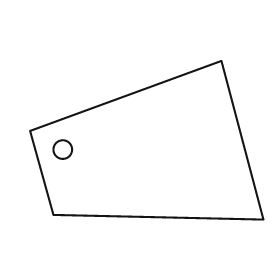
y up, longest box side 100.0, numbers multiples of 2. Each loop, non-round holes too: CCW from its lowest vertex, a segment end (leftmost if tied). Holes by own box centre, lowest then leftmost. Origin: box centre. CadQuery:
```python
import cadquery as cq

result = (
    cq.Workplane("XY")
    .moveTo(50.0, -34.0)
    .lineTo(32.0, 34.0)
    .lineTo(-50.0, 4.0)
    .lineTo(-40.0, -32.0)
    .close()
    .moveTo(-36.0, -4.0)
    .circle(4.0)
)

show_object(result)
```